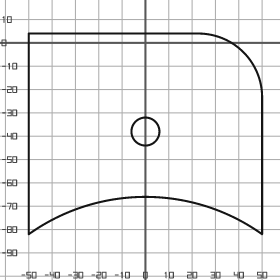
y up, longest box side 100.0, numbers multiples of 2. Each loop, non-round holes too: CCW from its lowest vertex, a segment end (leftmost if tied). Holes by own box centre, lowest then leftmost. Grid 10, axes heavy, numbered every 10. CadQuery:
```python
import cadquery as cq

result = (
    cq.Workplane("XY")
    .moveTo(-50.0, -82.0)
    .threePointArc((0.0, -66.0), (50.0, -82.0))
    .lineTo(50.0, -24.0)
    .threePointArc((42.0, -4.0), (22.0, 4.0))
    .lineTo(-50.0, 4.0)
    .close()
    .moveTo(0.0, -38.0)
    .circle(6.0)
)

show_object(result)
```